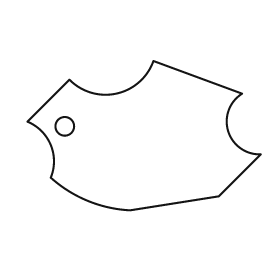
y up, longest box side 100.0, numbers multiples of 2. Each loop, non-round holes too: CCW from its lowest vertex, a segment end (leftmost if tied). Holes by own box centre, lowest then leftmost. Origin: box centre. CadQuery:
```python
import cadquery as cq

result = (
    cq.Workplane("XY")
    .moveTo(-6.0, -32.0)
    .lineTo(32.0, -26.0)
    .lineTo(50.0, -8.0)
    .threePointArc((36.0, 2.0), (42.0, 18.0))
    .lineTo(4.0, 32.0)
    .threePointArc((-12.0, 18.0), (-32.0, 24.0))
    .lineTo(-50.0, 6.0)
    .threePointArc((-40.0, -4.0), (-40.0, -18.0))
    .threePointArc((-24.0, -28.0), (-6.0, -32.0))
    .close()
    .moveTo(-34.0, 4.0)
    .circle(4.0)
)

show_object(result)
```